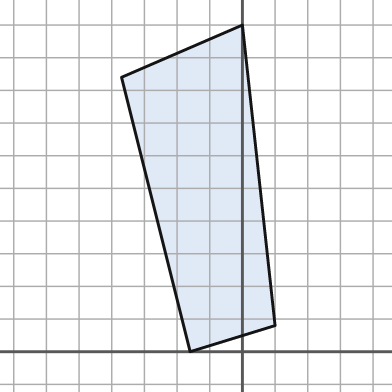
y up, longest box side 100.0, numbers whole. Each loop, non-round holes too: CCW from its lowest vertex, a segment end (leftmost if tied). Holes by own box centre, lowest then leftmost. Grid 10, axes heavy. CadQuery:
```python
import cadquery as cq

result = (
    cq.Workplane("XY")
    .moveTo(-16.0, 0.0)
    .lineTo(10.0, 8.0)
    .lineTo(0.0, 100.0)
    .lineTo(-37.0, 84.0)
    .close()
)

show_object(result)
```